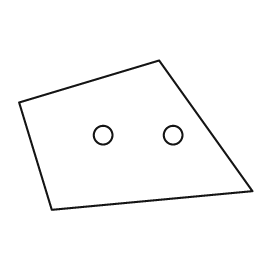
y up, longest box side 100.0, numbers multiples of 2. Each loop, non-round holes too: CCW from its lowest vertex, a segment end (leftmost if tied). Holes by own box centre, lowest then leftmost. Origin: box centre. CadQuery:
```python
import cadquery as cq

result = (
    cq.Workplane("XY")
    .moveTo(-36.0, -32.0)
    .lineTo(50.0, -24.0)
    .lineTo(10.0, 32.0)
    .lineTo(-50.0, 14.0)
    .close()
    .moveTo(-14.0, 0.0)
    .circle(4.0)
    .moveTo(16.0, 0.0)
    .circle(4.0)
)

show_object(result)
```